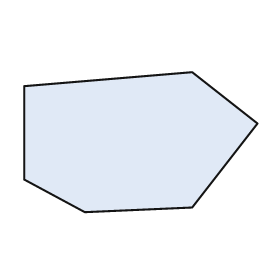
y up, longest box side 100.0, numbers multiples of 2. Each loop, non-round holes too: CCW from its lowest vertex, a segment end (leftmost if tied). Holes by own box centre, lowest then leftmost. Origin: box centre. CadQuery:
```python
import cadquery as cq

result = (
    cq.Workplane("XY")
    .moveTo(-24.0, -30.0)
    .lineTo(22.0, -28.0)
    .lineTo(50.0, 8.0)
    .lineTo(22.0, 30.0)
    .lineTo(-50.0, 24.0)
    .lineTo(-50.0, -16.0)
    .close()
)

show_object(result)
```